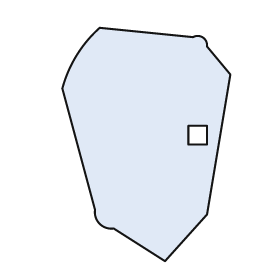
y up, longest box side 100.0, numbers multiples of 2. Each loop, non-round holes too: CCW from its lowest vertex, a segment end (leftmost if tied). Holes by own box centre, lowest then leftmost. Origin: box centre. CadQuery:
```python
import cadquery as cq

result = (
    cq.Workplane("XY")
    .moveTo(8.0, -50.0)
    .lineTo(26.0, -30.0)
    .lineTo(36.0, 30.0)
    .lineTo(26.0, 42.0)
    .threePointArc((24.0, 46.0), (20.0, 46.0))
    .lineTo(-20.0, 50.0)
    .threePointArc((-30.0, 38.0), (-36.0, 24.0))
    .lineTo(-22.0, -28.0)
    .threePointArc((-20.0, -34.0), (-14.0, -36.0))
    .close()
    .moveTo(18.0, 0.0)
    .lineTo(26.0, 0.0)
    .lineTo(26.0, 8.0)
    .lineTo(18.0, 8.0)
    .close()
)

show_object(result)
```